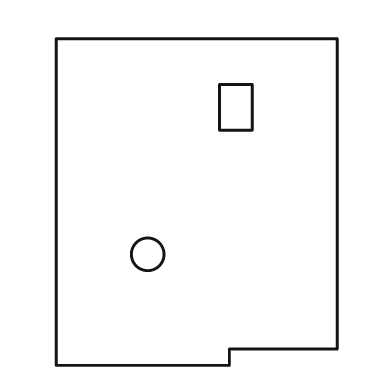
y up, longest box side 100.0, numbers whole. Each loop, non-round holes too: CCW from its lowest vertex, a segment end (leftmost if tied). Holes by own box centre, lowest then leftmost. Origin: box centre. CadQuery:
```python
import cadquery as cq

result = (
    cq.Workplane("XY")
    .moveTo(-43.0, -50.0)
    .lineTo(10.0, -50.0)
    .lineTo(10.0, -45.0)
    .lineTo(43.0, -45.0)
    .lineTo(43.0, 50.0)
    .lineTo(-43.0, 50.0)
    .close()
    .moveTo(-15.0, -16.0)
    .circle(5.0)
    .moveTo(7.0, 22.0)
    .lineTo(17.0, 22.0)
    .lineTo(17.0, 36.0)
    .lineTo(7.0, 36.0)
    .close()
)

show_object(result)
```